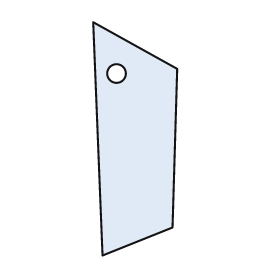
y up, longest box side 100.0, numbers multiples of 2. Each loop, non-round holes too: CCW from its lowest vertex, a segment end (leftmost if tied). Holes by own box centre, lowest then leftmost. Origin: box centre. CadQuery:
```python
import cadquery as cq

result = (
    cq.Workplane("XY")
    .moveTo(-14.0, -50.0)
    .lineTo(16.0, -38.0)
    .lineTo(18.0, 30.0)
    .lineTo(-18.0, 50.0)
    .close()
    .moveTo(-8.0, 28.0)
    .circle(4.0)
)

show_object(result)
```